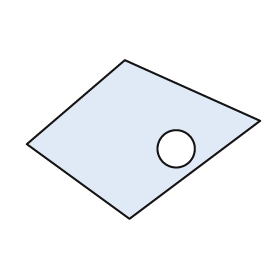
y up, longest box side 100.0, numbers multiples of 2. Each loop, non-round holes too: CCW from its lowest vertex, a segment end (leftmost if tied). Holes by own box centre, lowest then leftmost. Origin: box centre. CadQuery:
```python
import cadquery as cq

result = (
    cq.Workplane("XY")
    .moveTo(-6.0, -34.0)
    .lineTo(50.0, 8.0)
    .lineTo(-8.0, 34.0)
    .lineTo(-50.0, -2.0)
    .close()
    .moveTo(14.0, -4.0)
    .circle(8.0)
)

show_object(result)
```